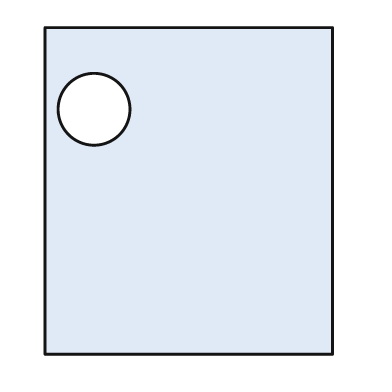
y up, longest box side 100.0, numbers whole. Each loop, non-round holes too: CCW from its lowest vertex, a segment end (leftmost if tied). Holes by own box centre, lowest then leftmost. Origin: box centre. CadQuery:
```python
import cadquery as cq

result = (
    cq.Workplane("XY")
    .moveTo(-44.0, -50.0)
    .lineTo(44.0, -50.0)
    .lineTo(44.0, 50.0)
    .lineTo(-44.0, 50.0)
    .close()
    .moveTo(-29.0, 25.0)
    .circle(11.0)
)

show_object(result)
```